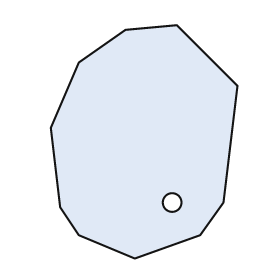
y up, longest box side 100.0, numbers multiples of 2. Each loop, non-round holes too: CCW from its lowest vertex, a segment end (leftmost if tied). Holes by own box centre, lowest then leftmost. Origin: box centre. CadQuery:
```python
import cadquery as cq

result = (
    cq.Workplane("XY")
    .moveTo(-4.0, -50.0)
    .lineTo(24.0, -40.0)
    .lineTo(34.0, -26.0)
    .lineTo(40.0, 24.0)
    .lineTo(14.0, 50.0)
    .lineTo(-8.0, 48.0)
    .lineTo(-28.0, 34.0)
    .lineTo(-40.0, 6.0)
    .lineTo(-36.0, -28.0)
    .lineTo(-28.0, -40.0)
    .close()
    .moveTo(12.0, -26.0)
    .circle(4.0)
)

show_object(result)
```